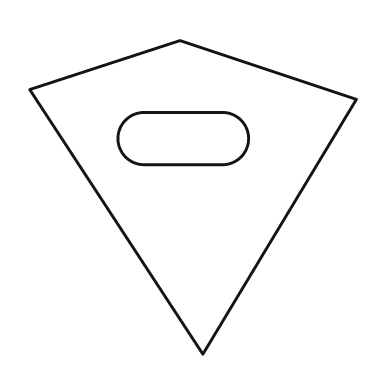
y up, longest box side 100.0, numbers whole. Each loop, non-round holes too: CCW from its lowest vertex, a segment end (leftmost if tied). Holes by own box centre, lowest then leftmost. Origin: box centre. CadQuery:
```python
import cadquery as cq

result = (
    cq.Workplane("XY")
    .moveTo(3.0, -48.0)
    .lineTo(50.0, 30.0)
    .lineTo(-4.0, 48.0)
    .lineTo(-50.0, 33.0)
    .close()
    .moveTo(-15.0, 10.0)
    .lineTo(9.0, 10.0)
    .threePointArc((17.0, 18.0), (9.0, 26.0))
    .lineTo(-15.0, 26.0)
    .threePointArc((-23.0, 18.0), (-15.0, 10.0))
    .close()
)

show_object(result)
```